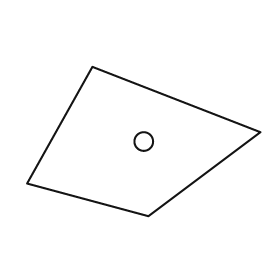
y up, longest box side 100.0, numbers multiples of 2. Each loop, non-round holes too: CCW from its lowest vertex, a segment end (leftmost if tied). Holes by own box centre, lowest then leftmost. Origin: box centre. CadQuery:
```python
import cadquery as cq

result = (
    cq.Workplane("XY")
    .moveTo(2.0, -32.0)
    .lineTo(50.0, 4.0)
    .lineTo(-22.0, 32.0)
    .lineTo(-50.0, -18.0)
    .close()
    .moveTo(0.0, 0.0)
    .circle(4.0)
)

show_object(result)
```